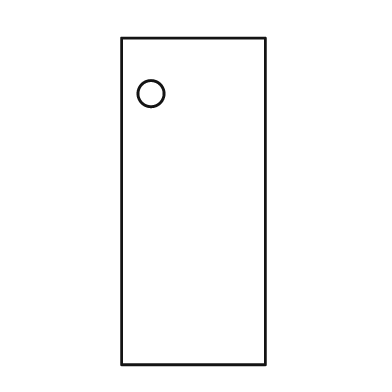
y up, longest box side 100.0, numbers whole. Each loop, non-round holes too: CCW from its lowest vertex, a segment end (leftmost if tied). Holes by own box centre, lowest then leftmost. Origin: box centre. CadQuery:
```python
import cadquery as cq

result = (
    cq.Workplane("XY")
    .moveTo(-22.0, -50.0)
    .lineTo(22.0, -50.0)
    .lineTo(22.0, 50.0)
    .lineTo(-22.0, 50.0)
    .close()
    .moveTo(-13.0, 33.0)
    .circle(4.0)
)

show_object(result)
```